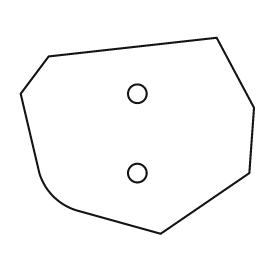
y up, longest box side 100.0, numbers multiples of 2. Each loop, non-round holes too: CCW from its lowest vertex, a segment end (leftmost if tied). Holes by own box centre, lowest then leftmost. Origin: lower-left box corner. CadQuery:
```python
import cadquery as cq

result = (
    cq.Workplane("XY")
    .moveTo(60.0, 0.0)
    .lineTo(98.0, 26.0)
    .lineTo(100.0, 54.0)
    .lineTo(84.0, 84.0)
    .lineTo(12.0, 76.0)
    .lineTo(0.0, 60.0)
    .lineTo(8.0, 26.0)
    .threePointArc((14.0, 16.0), (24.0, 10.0))
    .close()
    .moveTo(50.0, 26.0)
    .circle(4.0)
    .moveTo(50.0, 60.0)
    .circle(4.0)
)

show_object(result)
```